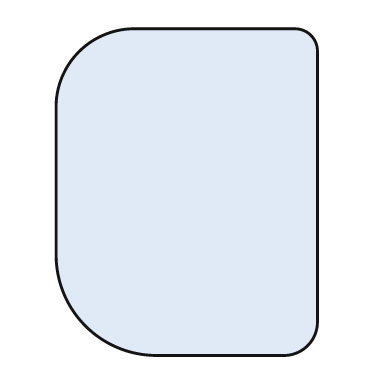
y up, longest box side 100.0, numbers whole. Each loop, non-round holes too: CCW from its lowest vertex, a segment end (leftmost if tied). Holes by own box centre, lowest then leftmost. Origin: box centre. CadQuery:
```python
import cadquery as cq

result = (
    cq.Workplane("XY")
    .moveTo(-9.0, -50.0)
    .lineTo(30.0, -50.0)
    .threePointArc((37.0, -47.0), (40.0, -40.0))
    .lineTo(40.0, 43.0)
    .threePointArc((38.0, 48.0), (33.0, 50.0))
    .lineTo(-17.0, 50.0)
    .threePointArc((-33.0, 43.0), (-40.0, 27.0))
    .lineTo(-40.0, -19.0)
    .threePointArc((-31.0, -41.0), (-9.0, -50.0))
    .close()
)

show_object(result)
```